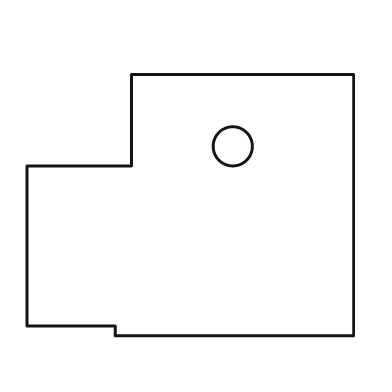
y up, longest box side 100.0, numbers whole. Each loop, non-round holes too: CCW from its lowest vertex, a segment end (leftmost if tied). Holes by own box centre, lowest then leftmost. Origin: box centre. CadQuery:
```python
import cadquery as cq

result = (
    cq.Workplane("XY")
    .moveTo(-23.0, -40.0)
    .lineTo(50.0, -40.0)
    .lineTo(50.0, 40.0)
    .lineTo(-18.0, 40.0)
    .lineTo(-18.0, 12.0)
    .lineTo(-50.0, 12.0)
    .lineTo(-50.0, -37.0)
    .lineTo(-23.0, -37.0)
    .close()
    .moveTo(13.0, 18.0)
    .circle(6.0)
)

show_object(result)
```